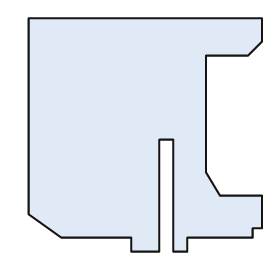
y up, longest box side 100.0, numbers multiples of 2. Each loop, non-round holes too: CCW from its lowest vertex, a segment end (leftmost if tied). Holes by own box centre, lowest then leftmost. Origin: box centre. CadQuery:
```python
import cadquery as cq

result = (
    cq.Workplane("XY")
    .moveTo(-6.0, -50.0)
    .lineTo(6.0, -50.0)
    .lineTo(6.0, -2.0)
    .lineTo(12.0, -2.0)
    .lineTo(12.0, -50.0)
    .lineTo(18.0, -50.0)
    .lineTo(18.0, -44.0)
    .lineTo(46.0, -44.0)
    .lineTo(46.0, -40.0)
    .lineTo(50.0, -40.0)
    .lineTo(50.0, -26.0)
    .lineTo(32.0, -26.0)
    .lineTo(26.0, -16.0)
    .lineTo(26.0, 34.0)
    .lineTo(44.0, 34.0)
    .lineTo(50.0, 40.0)
    .lineTo(50.0, 50.0)
    .lineTo(-50.0, 50.0)
    .lineTo(-50.0, -34.0)
    .lineTo(-36.0, -44.0)
    .lineTo(-6.0, -44.0)
    .close()
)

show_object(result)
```